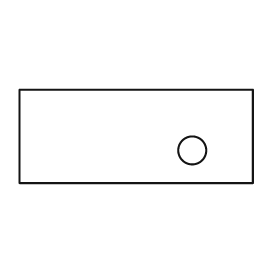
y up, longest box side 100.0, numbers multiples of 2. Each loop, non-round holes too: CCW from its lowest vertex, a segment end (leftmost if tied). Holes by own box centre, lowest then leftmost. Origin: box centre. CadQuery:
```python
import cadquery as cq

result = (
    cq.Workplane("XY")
    .moveTo(-50.0, -20.0)
    .lineTo(50.0, -20.0)
    .lineTo(50.0, 20.0)
    .lineTo(-50.0, 20.0)
    .close()
    .moveTo(24.0, -6.0)
    .circle(6.0)
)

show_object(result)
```